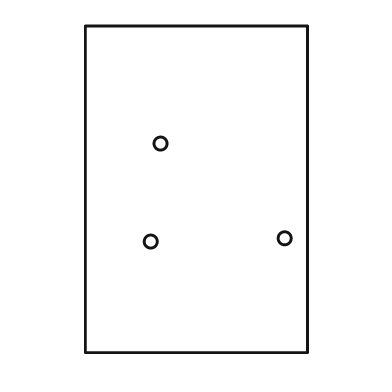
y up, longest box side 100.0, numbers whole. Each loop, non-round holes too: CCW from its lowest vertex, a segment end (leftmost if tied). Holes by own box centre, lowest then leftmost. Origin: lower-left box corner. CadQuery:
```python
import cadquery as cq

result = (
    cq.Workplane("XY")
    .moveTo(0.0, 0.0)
    .lineTo(68.0, 0.0)
    .lineTo(68.0, 100.0)
    .lineTo(0.0, 100.0)
    .close()
    .moveTo(20.0, 34.0)
    .circle(2.0)
    .moveTo(61.0, 35.0)
    .circle(2.0)
    .moveTo(23.0, 64.0)
    .circle(2.0)
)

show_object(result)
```